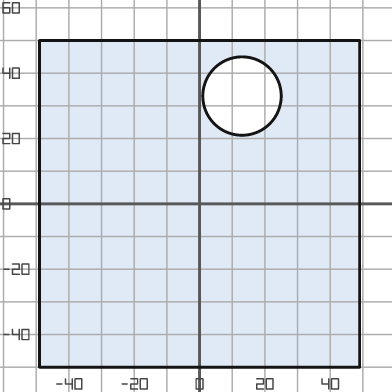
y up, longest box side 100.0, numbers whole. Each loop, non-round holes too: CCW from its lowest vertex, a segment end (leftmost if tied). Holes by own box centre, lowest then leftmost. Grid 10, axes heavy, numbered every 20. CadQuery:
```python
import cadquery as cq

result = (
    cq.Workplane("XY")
    .moveTo(-49.0, -50.0)
    .lineTo(49.0, -50.0)
    .lineTo(49.0, 50.0)
    .lineTo(-49.0, 50.0)
    .close()
    .moveTo(13.0, 33.0)
    .circle(12.0)
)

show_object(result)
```